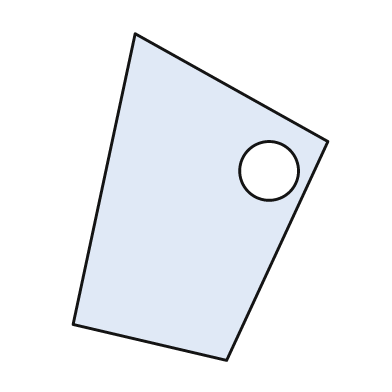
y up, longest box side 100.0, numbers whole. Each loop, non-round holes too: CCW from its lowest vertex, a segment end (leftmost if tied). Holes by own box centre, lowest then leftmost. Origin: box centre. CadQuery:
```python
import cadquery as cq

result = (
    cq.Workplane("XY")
    .moveTo(8.0, -50.0)
    .lineTo(39.0, 17.0)
    .lineTo(-20.0, 50.0)
    .lineTo(-39.0, -39.0)
    .close()
    .moveTo(21.0, 8.0)
    .circle(9.0)
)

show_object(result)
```